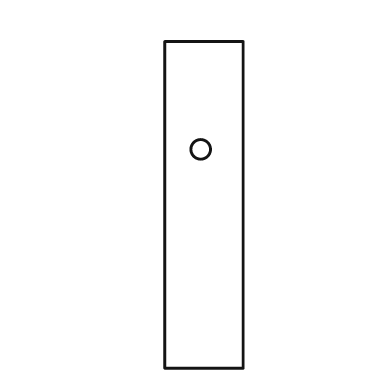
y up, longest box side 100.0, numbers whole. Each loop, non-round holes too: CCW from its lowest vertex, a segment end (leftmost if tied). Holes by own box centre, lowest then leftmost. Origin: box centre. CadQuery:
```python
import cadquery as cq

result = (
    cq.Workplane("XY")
    .moveTo(-12.0, -50.0)
    .lineTo(12.0, -50.0)
    .lineTo(12.0, 50.0)
    .lineTo(-12.0, 50.0)
    .close()
    .moveTo(-1.0, 17.0)
    .circle(3.0)
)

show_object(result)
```